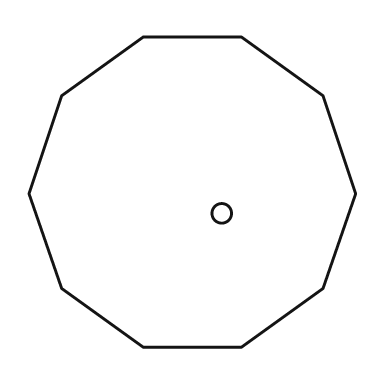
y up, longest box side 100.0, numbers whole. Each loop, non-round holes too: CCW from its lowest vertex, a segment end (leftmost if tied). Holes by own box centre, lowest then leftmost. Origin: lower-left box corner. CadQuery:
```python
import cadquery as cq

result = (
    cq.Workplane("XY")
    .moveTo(35.0, 0.0)
    .lineTo(65.0, 0.0)
    .lineTo(90.0, 18.0)
    .lineTo(100.0, 47.0)
    .lineTo(90.0, 77.0)
    .lineTo(65.0, 95.0)
    .lineTo(35.0, 95.0)
    .lineTo(10.0, 77.0)
    .lineTo(0.0, 47.0)
    .lineTo(10.0, 18.0)
    .close()
    .moveTo(59.0, 41.0)
    .circle(3.0)
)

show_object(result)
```